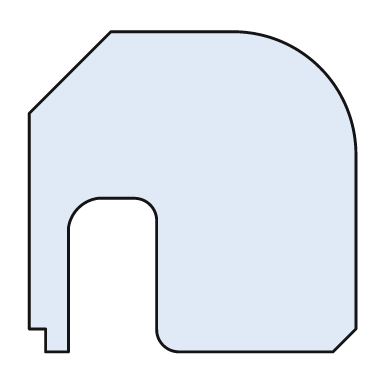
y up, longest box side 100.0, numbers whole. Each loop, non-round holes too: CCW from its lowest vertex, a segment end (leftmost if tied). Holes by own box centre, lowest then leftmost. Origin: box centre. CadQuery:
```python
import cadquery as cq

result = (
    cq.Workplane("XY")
    .moveTo(-45.0, -49.0)
    .lineTo(-38.0, -49.0)
    .lineTo(-38.0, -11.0)
    .threePointArc((-35.0, -5.0), (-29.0, -2.0))
    .lineTo(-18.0, -2.0)
    .threePointArc((-13.0, -4.0), (-11.0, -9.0))
    .lineTo(-11.0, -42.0)
    .threePointArc((-9.0, -47.0), (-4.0, -49.0))
    .lineTo(43.0, -49.0)
    .lineTo(50.0, -42.0)
    .lineTo(50.0, 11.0)
    .threePointArc((39.0, 38.0), (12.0, 49.0))
    .lineTo(-25.0, 49.0)
    .lineTo(-50.0, 24.0)
    .lineTo(-50.0, -42.0)
    .lineTo(-45.0, -42.0)
    .close()
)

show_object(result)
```